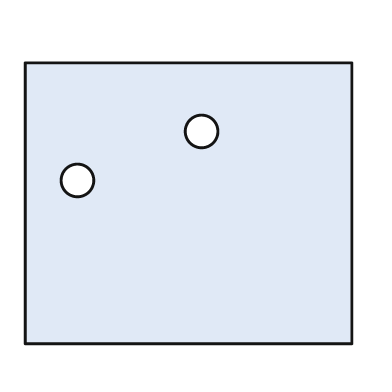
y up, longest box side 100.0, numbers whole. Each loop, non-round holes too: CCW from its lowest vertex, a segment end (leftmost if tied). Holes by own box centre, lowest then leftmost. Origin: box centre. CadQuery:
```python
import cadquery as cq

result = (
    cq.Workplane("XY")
    .moveTo(-50.0, -43.0)
    .lineTo(50.0, -43.0)
    .lineTo(50.0, 43.0)
    .lineTo(-50.0, 43.0)
    .close()
    .moveTo(-34.0, 7.0)
    .circle(5.0)
    .moveTo(4.0, 22.0)
    .circle(5.0)
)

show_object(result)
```